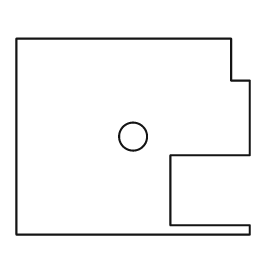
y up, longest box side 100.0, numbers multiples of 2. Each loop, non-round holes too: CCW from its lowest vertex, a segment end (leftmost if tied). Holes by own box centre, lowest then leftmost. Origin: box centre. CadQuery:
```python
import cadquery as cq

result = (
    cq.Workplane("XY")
    .moveTo(-50.0, -42.0)
    .lineTo(50.0, -42.0)
    .lineTo(50.0, -38.0)
    .lineTo(16.0, -38.0)
    .lineTo(16.0, -8.0)
    .lineTo(50.0, -8.0)
    .lineTo(50.0, 24.0)
    .lineTo(42.0, 24.0)
    .lineTo(42.0, 42.0)
    .lineTo(-50.0, 42.0)
    .close()
    .moveTo(0.0, 0.0)
    .circle(6.0)
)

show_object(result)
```